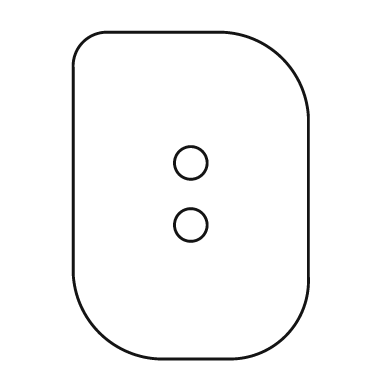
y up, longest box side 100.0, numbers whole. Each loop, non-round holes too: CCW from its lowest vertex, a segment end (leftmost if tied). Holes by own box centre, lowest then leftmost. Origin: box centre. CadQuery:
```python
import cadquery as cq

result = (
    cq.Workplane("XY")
    .moveTo(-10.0, -50.0)
    .lineTo(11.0, -50.0)
    .threePointArc((29.0, -43.0), (36.0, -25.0))
    .lineTo(36.0, 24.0)
    .threePointArc((28.0, 42.0), (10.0, 50.0))
    .lineTo(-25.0, 50.0)
    .threePointArc((-33.0, 47.0), (-36.0, 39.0))
    .lineTo(-36.0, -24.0)
    .threePointArc((-28.0, -42.0), (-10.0, -50.0))
    .close()
    .moveTo(0.0, -9.0)
    .circle(5.0)
    .moveTo(0.0, 10.0)
    .circle(5.0)
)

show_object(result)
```